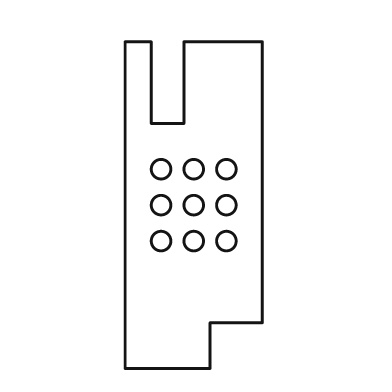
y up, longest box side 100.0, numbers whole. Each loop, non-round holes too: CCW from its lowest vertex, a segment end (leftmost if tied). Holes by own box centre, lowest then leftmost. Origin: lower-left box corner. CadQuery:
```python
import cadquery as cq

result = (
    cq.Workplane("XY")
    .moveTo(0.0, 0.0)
    .lineTo(26.0, 0.0)
    .lineTo(26.0, 14.0)
    .lineTo(42.0, 14.0)
    .lineTo(42.0, 100.0)
    .lineTo(18.0, 100.0)
    .lineTo(18.0, 75.0)
    .lineTo(8.0, 75.0)
    .lineTo(8.0, 100.0)
    .lineTo(0.0, 100.0)
    .close()
    .moveTo(11.0, 39.0)
    .circle(3.0)
    .moveTo(21.0, 39.0)
    .circle(3.0)
    .moveTo(31.0, 39.0)
    .circle(3.0)
    .moveTo(11.0, 50.0)
    .circle(3.0)
    .moveTo(21.0, 50.0)
    .circle(3.0)
    .moveTo(31.0, 50.0)
    .circle(3.0)
    .moveTo(11.0, 61.0)
    .circle(3.0)
    .moveTo(21.0, 61.0)
    .circle(3.0)
    .moveTo(31.0, 61.0)
    .circle(3.0)
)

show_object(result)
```